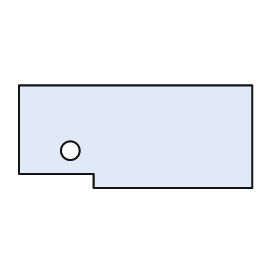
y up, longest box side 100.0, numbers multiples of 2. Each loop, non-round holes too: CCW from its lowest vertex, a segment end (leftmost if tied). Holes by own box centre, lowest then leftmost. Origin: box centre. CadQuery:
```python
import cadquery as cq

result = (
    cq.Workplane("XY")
    .moveTo(-18.0, -22.0)
    .lineTo(50.0, -22.0)
    .lineTo(50.0, 22.0)
    .lineTo(-50.0, 22.0)
    .lineTo(-50.0, -16.0)
    .lineTo(-18.0, -16.0)
    .close()
    .moveTo(-28.0, -6.0)
    .circle(4.0)
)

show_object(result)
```